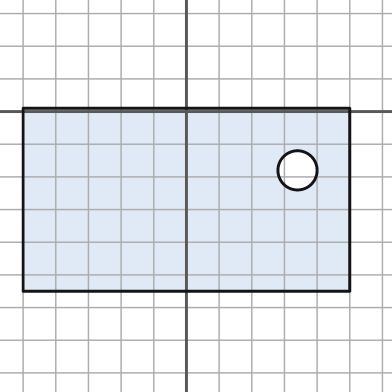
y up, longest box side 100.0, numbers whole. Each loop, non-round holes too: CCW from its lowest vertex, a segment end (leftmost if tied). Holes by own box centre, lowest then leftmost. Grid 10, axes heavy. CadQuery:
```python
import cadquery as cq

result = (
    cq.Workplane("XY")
    .moveTo(-50.0, -55.0)
    .lineTo(50.0, -55.0)
    .lineTo(50.0, 1.0)
    .lineTo(-50.0, 1.0)
    .close()
    .moveTo(34.0, -18.0)
    .circle(6.0)
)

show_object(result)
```